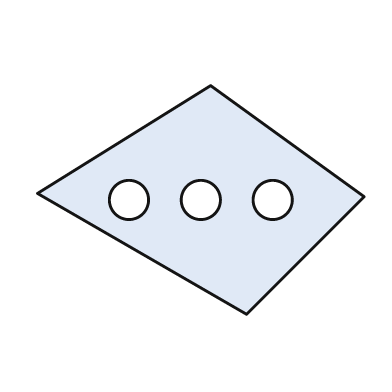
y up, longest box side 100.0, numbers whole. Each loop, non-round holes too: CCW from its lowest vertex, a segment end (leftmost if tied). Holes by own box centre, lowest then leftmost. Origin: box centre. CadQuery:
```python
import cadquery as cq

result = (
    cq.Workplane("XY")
    .moveTo(14.0, -35.0)
    .lineTo(50.0, 1.0)
    .lineTo(3.0, 35.0)
    .lineTo(-50.0, 2.0)
    .close()
    .moveTo(-22.0, 0.0)
    .circle(6.0)
    .moveTo(0.0, 0.0)
    .circle(6.0)
    .moveTo(22.0, 0.0)
    .circle(6.0)
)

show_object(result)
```